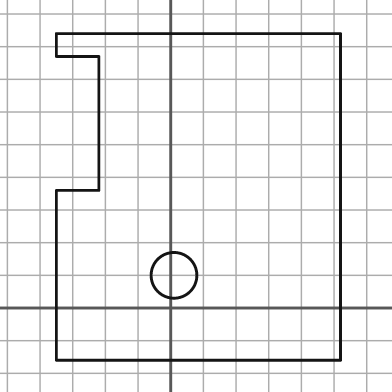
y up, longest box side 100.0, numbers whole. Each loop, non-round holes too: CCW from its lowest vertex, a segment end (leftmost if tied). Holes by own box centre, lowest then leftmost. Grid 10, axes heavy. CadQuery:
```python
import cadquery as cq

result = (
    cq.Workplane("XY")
    .moveTo(-35.0, -16.0)
    .lineTo(52.0, -16.0)
    .lineTo(52.0, 84.0)
    .lineTo(-35.0, 84.0)
    .lineTo(-35.0, 77.0)
    .lineTo(-22.0, 77.0)
    .lineTo(-22.0, 36.0)
    .lineTo(-35.0, 36.0)
    .close()
    .moveTo(1.0, 10.0)
    .circle(7.0)
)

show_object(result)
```